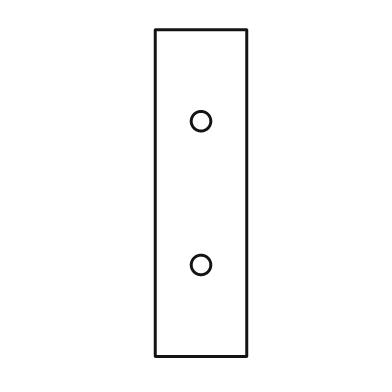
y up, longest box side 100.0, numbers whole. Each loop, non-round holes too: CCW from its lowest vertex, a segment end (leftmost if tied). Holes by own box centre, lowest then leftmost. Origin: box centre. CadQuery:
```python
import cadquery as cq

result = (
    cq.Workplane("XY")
    .moveTo(-14.0, -50.0)
    .lineTo(14.0, -50.0)
    .lineTo(14.0, 50.0)
    .lineTo(-14.0, 50.0)
    .close()
    .moveTo(0.0, -22.0)
    .circle(3.0)
    .moveTo(0.0, 22.0)
    .circle(3.0)
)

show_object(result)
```